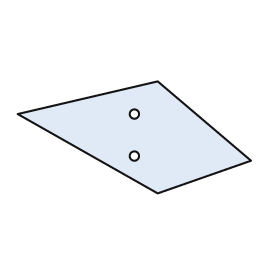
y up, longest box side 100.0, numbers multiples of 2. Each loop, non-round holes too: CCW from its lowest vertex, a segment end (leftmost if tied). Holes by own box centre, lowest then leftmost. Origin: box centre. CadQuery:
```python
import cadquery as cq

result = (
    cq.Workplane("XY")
    .moveTo(10.0, -24.0)
    .lineTo(50.0, -10.0)
    .lineTo(10.0, 24.0)
    .lineTo(-50.0, 10.0)
    .close()
    .moveTo(0.0, -8.0)
    .circle(2.0)
    .moveTo(0.0, 10.0)
    .circle(2.0)
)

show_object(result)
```